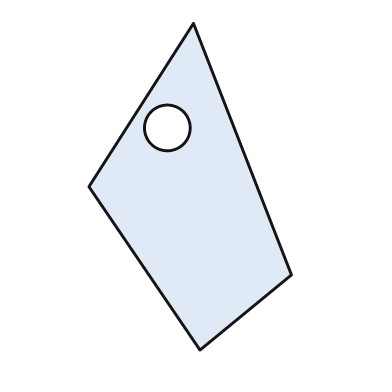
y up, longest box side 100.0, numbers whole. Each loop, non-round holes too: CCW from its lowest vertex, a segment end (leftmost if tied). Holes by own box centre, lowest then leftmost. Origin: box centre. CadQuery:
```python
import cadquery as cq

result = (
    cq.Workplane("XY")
    .moveTo(3.0, -50.0)
    .lineTo(31.0, -27.0)
    .lineTo(1.0, 50.0)
    .lineTo(-31.0, 0.0)
    .close()
    .moveTo(-7.0, 18.0)
    .circle(7.0)
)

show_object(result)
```